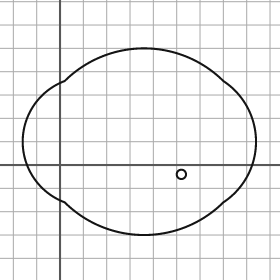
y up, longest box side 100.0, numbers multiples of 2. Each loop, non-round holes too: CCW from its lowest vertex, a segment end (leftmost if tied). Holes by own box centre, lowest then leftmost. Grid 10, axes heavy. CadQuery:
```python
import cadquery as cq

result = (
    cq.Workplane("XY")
    .moveTo(2.0, -16.0)
    .threePointArc((36.0, -30.0), (70.0, -16.0))
    .threePointArc((84.0, 10.0), (70.0, 36.0))
    .threePointArc((36.0, 50.0), (2.0, 36.0))
    .threePointArc((-16.0, 10.0), (2.0, -16.0))
    .close()
    .moveTo(52.0, -4.0)
    .circle(2.0)
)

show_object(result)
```